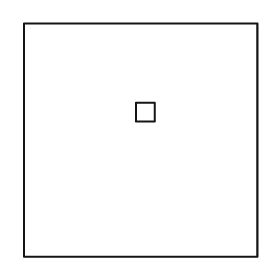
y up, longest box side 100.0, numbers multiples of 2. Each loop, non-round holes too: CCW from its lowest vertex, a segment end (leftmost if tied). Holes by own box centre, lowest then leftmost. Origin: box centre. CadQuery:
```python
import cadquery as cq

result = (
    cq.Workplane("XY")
    .moveTo(-50.0, -50.0)
    .lineTo(50.0, -50.0)
    .lineTo(50.0, 50.0)
    .lineTo(-50.0, 50.0)
    .close()
    .moveTo(-2.0, 8.0)
    .lineTo(6.0, 8.0)
    .lineTo(6.0, 16.0)
    .lineTo(-2.0, 16.0)
    .close()
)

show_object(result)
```